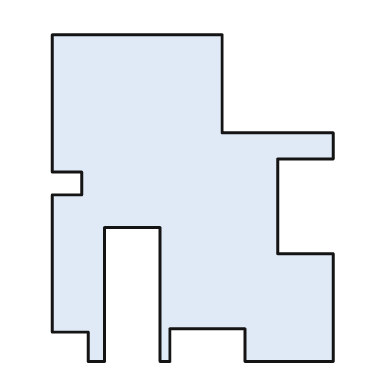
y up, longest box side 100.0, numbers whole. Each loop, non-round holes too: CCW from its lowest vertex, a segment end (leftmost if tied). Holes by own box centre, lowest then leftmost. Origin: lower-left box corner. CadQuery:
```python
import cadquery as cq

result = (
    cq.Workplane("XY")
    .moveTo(11.0, 0.0)
    .lineTo(16.0, 0.0)
    .lineTo(16.0, 41.0)
    .lineTo(33.0, 41.0)
    .lineTo(33.0, 0.0)
    .lineTo(36.0, 0.0)
    .lineTo(36.0, 10.0)
    .lineTo(59.0, 10.0)
    .lineTo(59.0, 0.0)
    .lineTo(86.0, 0.0)
    .lineTo(86.0, 33.0)
    .lineTo(69.0, 33.0)
    .lineTo(69.0, 62.0)
    .lineTo(86.0, 62.0)
    .lineTo(86.0, 70.0)
    .lineTo(52.0, 70.0)
    .lineTo(52.0, 100.0)
    .lineTo(0.0, 100.0)
    .lineTo(0.0, 58.0)
    .lineTo(9.0, 58.0)
    .lineTo(9.0, 51.0)
    .lineTo(0.0, 51.0)
    .lineTo(0.0, 9.0)
    .lineTo(11.0, 9.0)
    .close()
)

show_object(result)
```